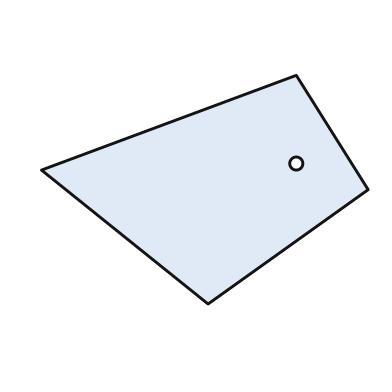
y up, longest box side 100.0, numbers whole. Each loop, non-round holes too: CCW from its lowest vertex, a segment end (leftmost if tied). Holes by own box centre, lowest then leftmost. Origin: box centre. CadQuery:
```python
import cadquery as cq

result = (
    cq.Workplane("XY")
    .moveTo(1.0, -35.0)
    .lineTo(50.0, 0.0)
    .lineTo(28.0, 35.0)
    .lineTo(-50.0, 6.0)
    .close()
    .moveTo(28.0, 8.0)
    .circle(2.0)
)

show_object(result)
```